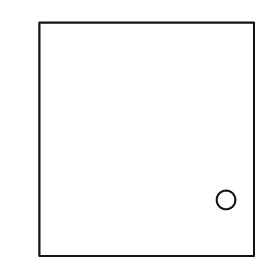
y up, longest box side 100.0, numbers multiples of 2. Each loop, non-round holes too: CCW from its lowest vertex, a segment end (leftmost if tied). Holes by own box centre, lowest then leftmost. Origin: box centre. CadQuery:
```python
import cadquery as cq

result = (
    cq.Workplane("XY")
    .moveTo(-46.0, -50.0)
    .lineTo(46.0, -50.0)
    .lineTo(46.0, 50.0)
    .lineTo(-46.0, 50.0)
    .close()
    .moveTo(34.0, -26.0)
    .circle(4.0)
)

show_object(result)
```